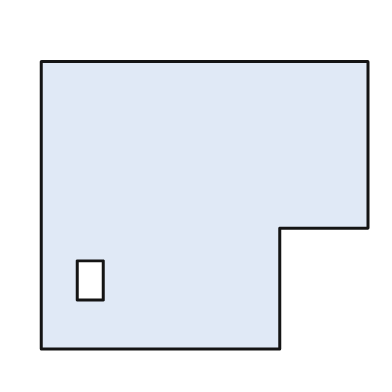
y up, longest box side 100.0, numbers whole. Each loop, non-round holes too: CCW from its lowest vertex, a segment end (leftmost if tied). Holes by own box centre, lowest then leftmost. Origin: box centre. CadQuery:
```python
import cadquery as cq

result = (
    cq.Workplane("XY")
    .moveTo(-50.0, -44.0)
    .lineTo(23.0, -44.0)
    .lineTo(23.0, -7.0)
    .lineTo(50.0, -7.0)
    .lineTo(50.0, 44.0)
    .lineTo(-50.0, 44.0)
    .close()
    .moveTo(-39.0, -29.0)
    .lineTo(-31.0, -29.0)
    .lineTo(-31.0, -17.0)
    .lineTo(-39.0, -17.0)
    .close()
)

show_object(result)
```